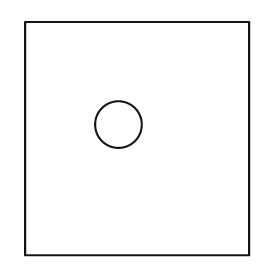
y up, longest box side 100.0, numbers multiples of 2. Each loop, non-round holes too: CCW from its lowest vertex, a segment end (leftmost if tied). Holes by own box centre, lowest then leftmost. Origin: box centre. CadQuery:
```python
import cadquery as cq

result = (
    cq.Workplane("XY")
    .moveTo(-48.0, -50.0)
    .lineTo(48.0, -50.0)
    .lineTo(48.0, 50.0)
    .lineTo(-48.0, 50.0)
    .close()
    .moveTo(-8.0, 6.0)
    .circle(10.0)
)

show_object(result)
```